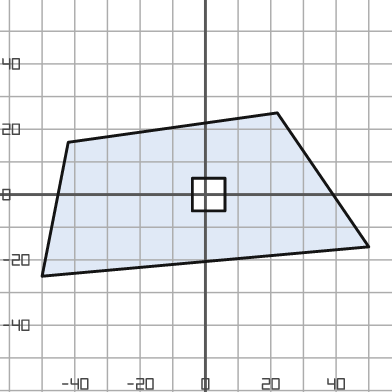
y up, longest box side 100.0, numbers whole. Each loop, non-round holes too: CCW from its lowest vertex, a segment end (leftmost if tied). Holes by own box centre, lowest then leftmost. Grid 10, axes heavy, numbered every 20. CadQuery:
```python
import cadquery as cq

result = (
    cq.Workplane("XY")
    .moveTo(-50.0, -25.0)
    .lineTo(50.0, -16.0)
    .lineTo(22.0, 25.0)
    .lineTo(-42.0, 16.0)
    .close()
    .moveTo(-4.0, -5.0)
    .lineTo(6.0, -5.0)
    .lineTo(6.0, 5.0)
    .lineTo(-4.0, 5.0)
    .close()
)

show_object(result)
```